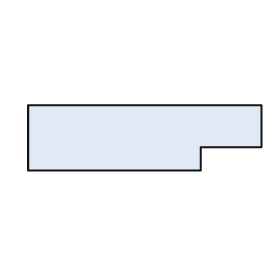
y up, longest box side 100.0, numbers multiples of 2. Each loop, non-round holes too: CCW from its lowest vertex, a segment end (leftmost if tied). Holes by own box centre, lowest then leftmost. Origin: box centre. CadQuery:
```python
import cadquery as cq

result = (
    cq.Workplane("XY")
    .moveTo(-50.0, -14.0)
    .lineTo(24.0, -14.0)
    .lineTo(24.0, -4.0)
    .lineTo(50.0, -4.0)
    .lineTo(50.0, 14.0)
    .lineTo(-50.0, 14.0)
    .close()
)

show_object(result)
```